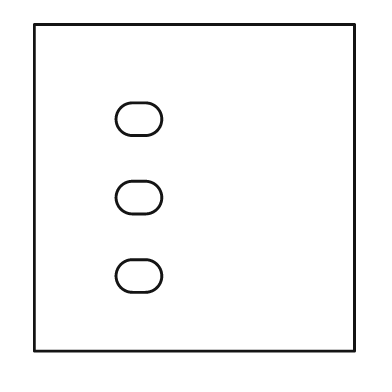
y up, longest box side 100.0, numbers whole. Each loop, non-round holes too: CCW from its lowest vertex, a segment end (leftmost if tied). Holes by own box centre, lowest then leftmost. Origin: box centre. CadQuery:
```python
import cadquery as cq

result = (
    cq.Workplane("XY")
    .moveTo(-49.0, -50.0)
    .lineTo(49.0, -50.0)
    .lineTo(49.0, 50.0)
    .lineTo(-49.0, 50.0)
    .close()
    .moveTo(-19.0, -32.0)
    .lineTo(-15.0, -32.0)
    .threePointArc((-10.0, -27.0), (-15.0, -22.0))
    .lineTo(-19.0, -22.0)
    .threePointArc((-24.0, -27.0), (-19.0, -32.0))
    .close()
    .moveTo(-19.0, -8.0)
    .lineTo(-15.0, -8.0)
    .threePointArc((-10.0, -3.0), (-15.0, 2.0))
    .lineTo(-19.0, 2.0)
    .threePointArc((-24.0, -3.0), (-19.0, -8.0))
    .close()
    .moveTo(-19.0, 16.0)
    .lineTo(-15.0, 16.0)
    .threePointArc((-10.0, 21.0), (-15.0, 26.0))
    .lineTo(-19.0, 26.0)
    .threePointArc((-24.0, 21.0), (-19.0, 16.0))
    .close()
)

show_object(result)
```